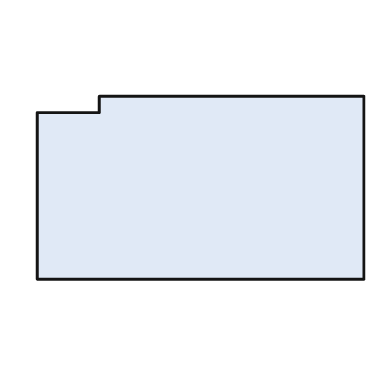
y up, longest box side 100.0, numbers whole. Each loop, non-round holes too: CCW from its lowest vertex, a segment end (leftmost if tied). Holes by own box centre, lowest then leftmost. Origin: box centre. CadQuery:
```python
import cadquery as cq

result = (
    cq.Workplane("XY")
    .moveTo(-50.0, -28.0)
    .lineTo(50.0, -28.0)
    .lineTo(50.0, 28.0)
    .lineTo(-31.0, 28.0)
    .lineTo(-31.0, 23.0)
    .lineTo(-50.0, 23.0)
    .close()
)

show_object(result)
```